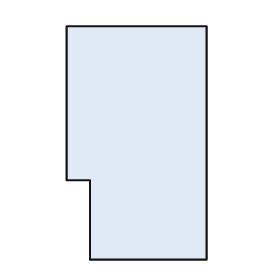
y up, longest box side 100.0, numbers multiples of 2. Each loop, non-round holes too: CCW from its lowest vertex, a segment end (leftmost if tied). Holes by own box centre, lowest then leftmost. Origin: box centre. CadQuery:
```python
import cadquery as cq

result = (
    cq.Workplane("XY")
    .moveTo(-20.0, -50.0)
    .lineTo(30.0, -50.0)
    .lineTo(30.0, 50.0)
    .lineTo(-30.0, 50.0)
    .lineTo(-30.0, -16.0)
    .lineTo(-20.0, -16.0)
    .close()
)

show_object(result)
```